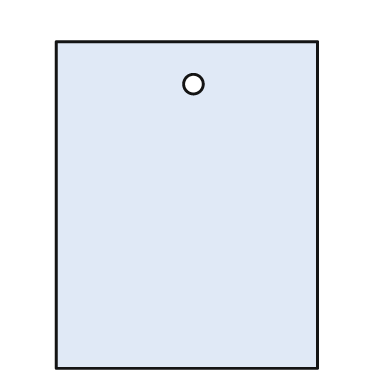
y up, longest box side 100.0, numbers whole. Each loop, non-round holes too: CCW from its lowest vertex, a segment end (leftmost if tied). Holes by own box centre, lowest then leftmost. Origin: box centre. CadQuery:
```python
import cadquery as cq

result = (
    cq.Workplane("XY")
    .moveTo(-40.0, -50.0)
    .lineTo(40.0, -50.0)
    .lineTo(40.0, 50.0)
    .lineTo(-40.0, 50.0)
    .close()
    .moveTo(2.0, 37.0)
    .circle(3.0)
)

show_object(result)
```